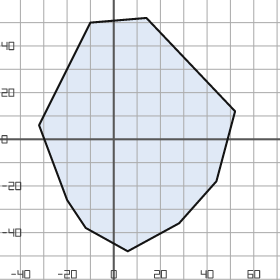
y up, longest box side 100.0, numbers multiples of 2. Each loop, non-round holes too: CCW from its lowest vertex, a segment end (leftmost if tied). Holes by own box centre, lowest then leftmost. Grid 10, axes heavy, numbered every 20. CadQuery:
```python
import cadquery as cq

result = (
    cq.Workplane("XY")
    .moveTo(6.0, -48.0)
    .lineTo(28.0, -36.0)
    .lineTo(44.0, -18.0)
    .lineTo(52.0, 12.0)
    .lineTo(14.0, 52.0)
    .lineTo(-10.0, 50.0)
    .lineTo(-32.0, 6.0)
    .lineTo(-20.0, -26.0)
    .lineTo(-12.0, -38.0)
    .close()
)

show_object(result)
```